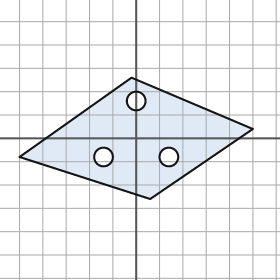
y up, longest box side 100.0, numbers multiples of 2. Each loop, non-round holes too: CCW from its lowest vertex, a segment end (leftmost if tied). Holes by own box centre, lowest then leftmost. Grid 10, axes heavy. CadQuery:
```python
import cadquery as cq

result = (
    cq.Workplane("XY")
    .moveTo(6.0, -26.0)
    .lineTo(50.0, 4.0)
    .lineTo(-2.0, 26.0)
    .lineTo(-50.0, -8.0)
    .close()
    .moveTo(-14.0, -8.0)
    .circle(4.0)
    .moveTo(14.0, -8.0)
    .circle(4.0)
    .moveTo(0.0, 16.0)
    .circle(4.0)
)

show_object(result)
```